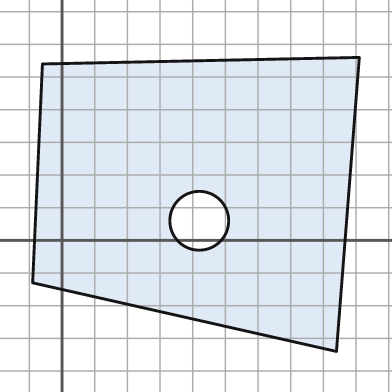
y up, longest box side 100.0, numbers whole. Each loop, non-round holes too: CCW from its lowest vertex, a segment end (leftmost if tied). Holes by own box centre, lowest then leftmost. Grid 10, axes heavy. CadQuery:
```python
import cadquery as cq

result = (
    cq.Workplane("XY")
    .moveTo(84.0, -34.0)
    .lineTo(91.0, 56.0)
    .lineTo(-6.0, 54.0)
    .lineTo(-9.0, -13.0)
    .close()
    .moveTo(42.0, 6.0)
    .circle(9.0)
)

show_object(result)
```